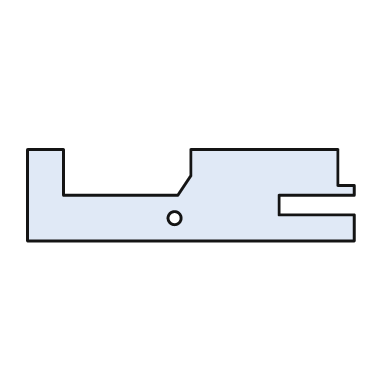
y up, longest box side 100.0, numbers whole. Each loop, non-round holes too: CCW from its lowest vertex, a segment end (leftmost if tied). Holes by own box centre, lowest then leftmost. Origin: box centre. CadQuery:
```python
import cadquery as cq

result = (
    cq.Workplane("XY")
    .moveTo(-50.0, -14.0)
    .lineTo(50.0, -14.0)
    .lineTo(50.0, -6.0)
    .lineTo(27.0, -6.0)
    .lineTo(27.0, 0.0)
    .lineTo(50.0, 0.0)
    .lineTo(50.0, 3.0)
    .lineTo(45.0, 3.0)
    .lineTo(45.0, 14.0)
    .lineTo(0.0, 14.0)
    .lineTo(0.0, 6.0)
    .lineTo(-4.0, 0.0)
    .lineTo(-39.0, 0.0)
    .lineTo(-39.0, 14.0)
    .lineTo(-50.0, 14.0)
    .close()
    .moveTo(-5.0, -7.0)
    .circle(2.0)
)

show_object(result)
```